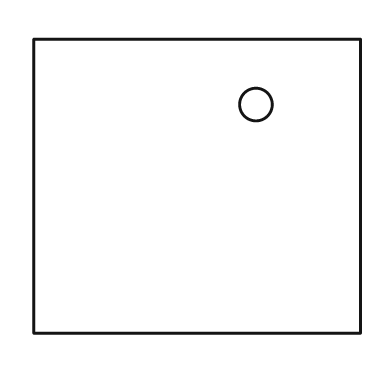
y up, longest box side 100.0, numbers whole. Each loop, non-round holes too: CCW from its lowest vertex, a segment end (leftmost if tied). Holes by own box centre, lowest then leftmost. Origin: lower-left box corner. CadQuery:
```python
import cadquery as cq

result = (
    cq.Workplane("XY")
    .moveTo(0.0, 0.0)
    .lineTo(100.0, 0.0)
    .lineTo(100.0, 90.0)
    .lineTo(0.0, 90.0)
    .close()
    .moveTo(68.0, 70.0)
    .circle(5.0)
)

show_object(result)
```